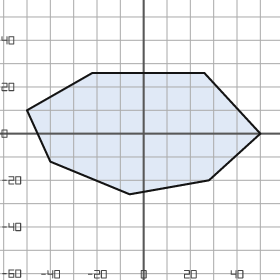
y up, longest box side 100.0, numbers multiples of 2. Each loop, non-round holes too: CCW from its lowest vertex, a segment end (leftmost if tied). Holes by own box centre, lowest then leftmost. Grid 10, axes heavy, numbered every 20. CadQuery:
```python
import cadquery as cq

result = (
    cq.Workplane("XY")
    .moveTo(-6.0, -26.0)
    .lineTo(28.0, -20.0)
    .lineTo(50.0, 0.0)
    .lineTo(26.0, 26.0)
    .lineTo(-22.0, 26.0)
    .lineTo(-50.0, 10.0)
    .lineTo(-40.0, -12.0)
    .close()
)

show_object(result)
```